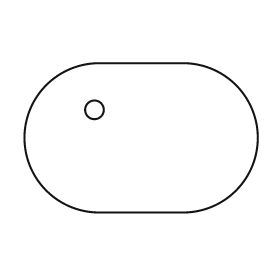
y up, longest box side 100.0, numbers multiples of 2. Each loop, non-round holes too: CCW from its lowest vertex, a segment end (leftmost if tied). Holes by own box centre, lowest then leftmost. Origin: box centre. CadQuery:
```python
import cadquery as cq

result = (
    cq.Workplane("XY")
    .moveTo(-18.0, -32.0)
    .lineTo(18.0, -32.0)
    .threePointArc((50.0, 0.0), (18.0, 32.0))
    .lineTo(-18.0, 32.0)
    .threePointArc((-50.0, 0.0), (-18.0, -32.0))
    .close()
    .moveTo(-20.0, 12.0)
    .circle(4.0)
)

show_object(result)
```